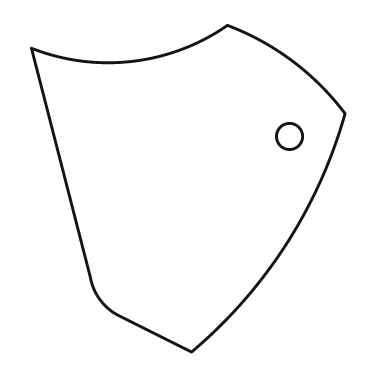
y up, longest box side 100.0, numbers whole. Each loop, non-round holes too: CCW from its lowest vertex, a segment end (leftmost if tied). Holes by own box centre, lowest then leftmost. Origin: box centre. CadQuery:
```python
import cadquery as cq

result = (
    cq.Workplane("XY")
    .moveTo(1.0, -50.0)
    .threePointArc((30.0, -17.0), (48.0, 23.0))
    .threePointArc((32.0, 39.0), (12.0, 50.0))
    .threePointArc((-17.0, 39.0), (-48.0, 43.0))
    .lineTo(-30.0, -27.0)
    .threePointArc((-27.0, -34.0), (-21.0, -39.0))
    .close()
    .moveTo(31.0, 16.0)
    .circle(4.0)
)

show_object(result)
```